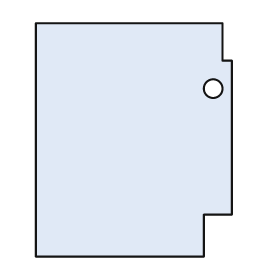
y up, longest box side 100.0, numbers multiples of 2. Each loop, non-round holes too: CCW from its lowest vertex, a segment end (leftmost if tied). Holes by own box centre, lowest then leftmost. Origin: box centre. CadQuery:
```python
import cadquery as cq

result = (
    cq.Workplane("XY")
    .moveTo(-42.0, -50.0)
    .lineTo(30.0, -50.0)
    .lineTo(30.0, -32.0)
    .lineTo(42.0, -32.0)
    .lineTo(42.0, 34.0)
    .lineTo(38.0, 34.0)
    .lineTo(38.0, 50.0)
    .lineTo(-42.0, 50.0)
    .close()
    .moveTo(34.0, 22.0)
    .circle(4.0)
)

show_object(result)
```